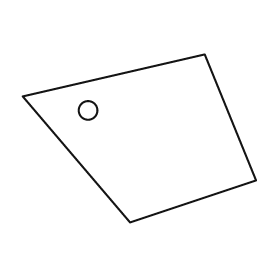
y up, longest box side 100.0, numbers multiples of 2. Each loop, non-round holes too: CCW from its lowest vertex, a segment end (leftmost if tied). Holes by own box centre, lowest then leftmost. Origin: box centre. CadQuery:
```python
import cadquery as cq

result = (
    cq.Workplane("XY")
    .moveTo(-4.0, -36.0)
    .lineTo(50.0, -18.0)
    .lineTo(28.0, 36.0)
    .lineTo(-50.0, 18.0)
    .close()
    .moveTo(-22.0, 12.0)
    .circle(4.0)
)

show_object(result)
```